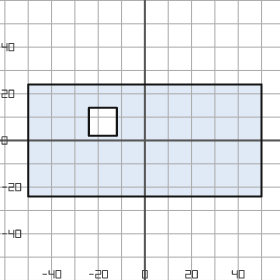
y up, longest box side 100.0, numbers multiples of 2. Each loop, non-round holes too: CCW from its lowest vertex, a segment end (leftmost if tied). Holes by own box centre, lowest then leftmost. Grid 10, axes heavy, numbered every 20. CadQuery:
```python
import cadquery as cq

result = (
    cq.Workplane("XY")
    .moveTo(-50.0, -24.0)
    .lineTo(50.0, -24.0)
    .lineTo(50.0, 24.0)
    .lineTo(-50.0, 24.0)
    .close()
    .moveTo(-24.0, 2.0)
    .lineTo(-12.0, 2.0)
    .lineTo(-12.0, 14.0)
    .lineTo(-24.0, 14.0)
    .close()
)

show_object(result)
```